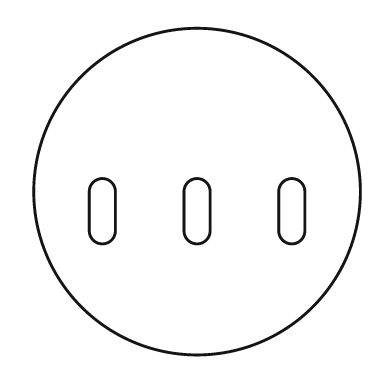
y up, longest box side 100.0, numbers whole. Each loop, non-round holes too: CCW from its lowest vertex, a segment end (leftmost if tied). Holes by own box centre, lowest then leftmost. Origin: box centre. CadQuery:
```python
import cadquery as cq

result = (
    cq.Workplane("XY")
    .moveTo(0.0, 0.0)
    .circle(50.0)
    .moveTo(-33.0, -12.0)
    .threePointArc((-29.0, -16.0), (-25.0, -12.0))
    .lineTo(-25.0, 0.0)
    .threePointArc((-29.0, 4.0), (-33.0, 0.0))
    .close()
    .moveTo(-4.0, -12.0)
    .threePointArc((0.0, -16.0), (4.0, -12.0))
    .lineTo(4.0, 0.0)
    .threePointArc((0.0, 4.0), (-4.0, 0.0))
    .close()
    .moveTo(25.0, -12.0)
    .threePointArc((29.0, -16.0), (33.0, -12.0))
    .lineTo(33.0, 0.0)
    .threePointArc((29.0, 4.0), (25.0, 0.0))
    .close()
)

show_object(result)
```